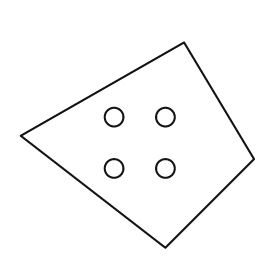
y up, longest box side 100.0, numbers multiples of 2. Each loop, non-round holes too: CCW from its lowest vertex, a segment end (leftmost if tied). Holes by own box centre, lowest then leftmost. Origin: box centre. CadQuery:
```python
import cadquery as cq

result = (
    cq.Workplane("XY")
    .moveTo(12.0, -44.0)
    .lineTo(50.0, -6.0)
    .lineTo(20.0, 44.0)
    .lineTo(-50.0, 4.0)
    .close()
    .moveTo(-10.0, -10.0)
    .circle(4.0)
    .moveTo(12.0, -10.0)
    .circle(4.0)
    .moveTo(-10.0, 12.0)
    .circle(4.0)
    .moveTo(12.0, 12.0)
    .circle(4.0)
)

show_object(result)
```